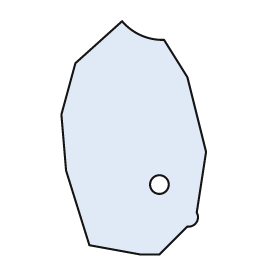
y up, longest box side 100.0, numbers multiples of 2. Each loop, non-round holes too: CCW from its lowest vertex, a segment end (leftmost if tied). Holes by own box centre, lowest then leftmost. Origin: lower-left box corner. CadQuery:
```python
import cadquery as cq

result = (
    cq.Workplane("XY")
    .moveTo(34.0, 0.0)
    .lineTo(42.0, 0.0)
    .lineTo(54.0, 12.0)
    .threePointArc((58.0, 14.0), (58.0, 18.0))
    .lineTo(62.0, 44.0)
    .lineTo(54.0, 76.0)
    .lineTo(44.0, 92.0)
    .threePointArc((34.0, 94.0), (26.0, 100.0))
    .lineTo(6.0, 82.0)
    .lineTo(0.0, 60.0)
    .lineTo(2.0, 36.0)
    .lineTo(12.0, 4.0)
    .close()
    .moveTo(42.0, 30.0)
    .circle(4.0)
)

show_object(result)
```